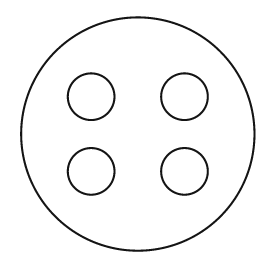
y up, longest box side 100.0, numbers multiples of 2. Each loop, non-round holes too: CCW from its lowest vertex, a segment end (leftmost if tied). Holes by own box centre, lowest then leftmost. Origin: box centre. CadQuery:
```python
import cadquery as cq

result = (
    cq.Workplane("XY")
    .moveTo(0.0, 0.0)
    .circle(50.0)
    .moveTo(-20.0, -16.0)
    .circle(10.0)
    .moveTo(20.0, -16.0)
    .circle(10.0)
    .moveTo(-20.0, 16.0)
    .circle(10.0)
    .moveTo(20.0, 16.0)
    .circle(10.0)
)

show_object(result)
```